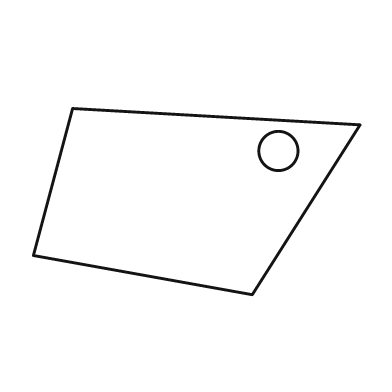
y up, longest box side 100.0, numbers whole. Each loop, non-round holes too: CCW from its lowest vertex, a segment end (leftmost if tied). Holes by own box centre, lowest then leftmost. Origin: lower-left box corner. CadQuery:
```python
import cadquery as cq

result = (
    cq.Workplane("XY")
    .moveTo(67.0, 0.0)
    .lineTo(100.0, 52.0)
    .lineTo(12.0, 57.0)
    .lineTo(0.0, 12.0)
    .close()
    .moveTo(75.0, 44.0)
    .circle(6.0)
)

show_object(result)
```